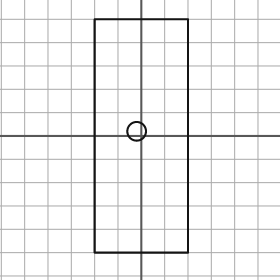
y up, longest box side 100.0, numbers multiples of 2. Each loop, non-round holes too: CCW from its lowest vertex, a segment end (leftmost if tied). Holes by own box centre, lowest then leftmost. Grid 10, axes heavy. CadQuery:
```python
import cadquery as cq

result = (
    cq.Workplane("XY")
    .moveTo(-20.0, -50.0)
    .lineTo(20.0, -50.0)
    .lineTo(20.0, 50.0)
    .lineTo(-20.0, 50.0)
    .close()
    .moveTo(-2.0, 2.0)
    .circle(4.0)
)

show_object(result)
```